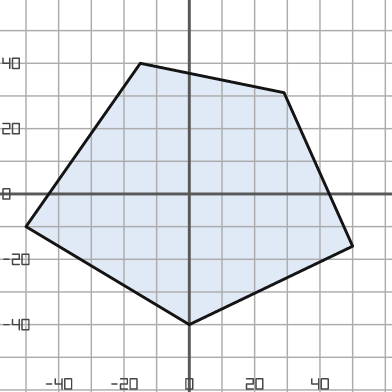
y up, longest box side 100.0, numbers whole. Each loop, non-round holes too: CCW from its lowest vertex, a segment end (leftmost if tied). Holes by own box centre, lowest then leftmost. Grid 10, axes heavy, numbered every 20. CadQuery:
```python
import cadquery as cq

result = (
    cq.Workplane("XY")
    .moveTo(0.0, -40.0)
    .lineTo(50.0, -16.0)
    .lineTo(29.0, 31.0)
    .lineTo(-15.0, 40.0)
    .lineTo(-50.0, -10.0)
    .close()
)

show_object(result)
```